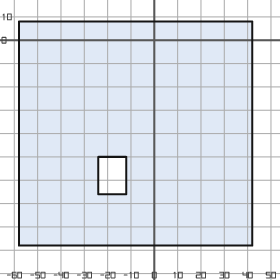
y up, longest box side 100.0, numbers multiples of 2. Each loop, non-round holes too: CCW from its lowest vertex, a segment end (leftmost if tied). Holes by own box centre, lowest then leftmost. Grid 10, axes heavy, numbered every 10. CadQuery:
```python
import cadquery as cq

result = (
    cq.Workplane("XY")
    .moveTo(-58.0, -88.0)
    .lineTo(42.0, -88.0)
    .lineTo(42.0, 8.0)
    .lineTo(-58.0, 8.0)
    .close()
    .moveTo(-24.0, -66.0)
    .lineTo(-12.0, -66.0)
    .lineTo(-12.0, -50.0)
    .lineTo(-24.0, -50.0)
    .close()
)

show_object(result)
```